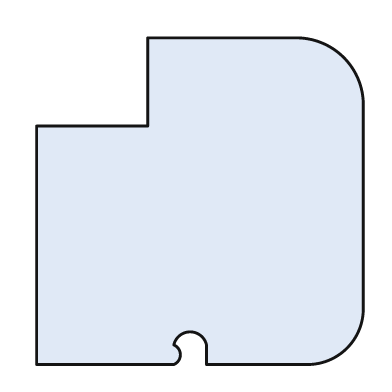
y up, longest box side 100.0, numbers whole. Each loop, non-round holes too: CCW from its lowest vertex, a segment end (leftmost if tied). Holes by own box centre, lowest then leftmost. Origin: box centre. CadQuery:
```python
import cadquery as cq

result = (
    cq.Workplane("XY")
    .moveTo(-50.0, -50.0)
    .lineTo(-8.0, -50.0)
    .threePointArc((-6.0, -47.0), (-8.0, -44.0))
    .threePointArc((-3.0, -40.0), (2.0, -44.0))
    .lineTo(2.0, -50.0)
    .lineTo(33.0, -50.0)
    .threePointArc((45.0, -45.0), (50.0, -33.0))
    .lineTo(50.0, 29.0)
    .threePointArc((44.0, 44.0), (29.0, 50.0))
    .lineTo(-16.0, 50.0)
    .lineTo(-16.0, 23.0)
    .lineTo(-50.0, 23.0)
    .close()
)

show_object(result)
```